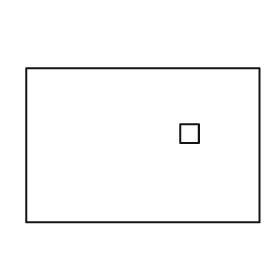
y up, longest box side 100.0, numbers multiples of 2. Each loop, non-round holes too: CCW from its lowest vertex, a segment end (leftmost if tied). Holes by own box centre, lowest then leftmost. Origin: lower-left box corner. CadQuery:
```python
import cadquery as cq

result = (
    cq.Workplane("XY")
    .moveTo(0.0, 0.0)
    .lineTo(100.0, 0.0)
    .lineTo(100.0, 66.0)
    .lineTo(0.0, 66.0)
    .close()
    .moveTo(66.0, 34.0)
    .lineTo(74.0, 34.0)
    .lineTo(74.0, 42.0)
    .lineTo(66.0, 42.0)
    .close()
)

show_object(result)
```